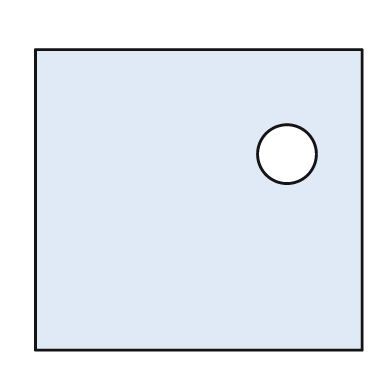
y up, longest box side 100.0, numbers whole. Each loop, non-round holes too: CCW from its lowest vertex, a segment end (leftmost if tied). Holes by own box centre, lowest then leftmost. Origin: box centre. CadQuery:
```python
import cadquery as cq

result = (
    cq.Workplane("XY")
    .moveTo(-50.0, -46.0)
    .lineTo(50.0, -46.0)
    .lineTo(50.0, 46.0)
    .lineTo(-50.0, 46.0)
    .close()
    .moveTo(27.0, 14.0)
    .circle(9.0)
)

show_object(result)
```